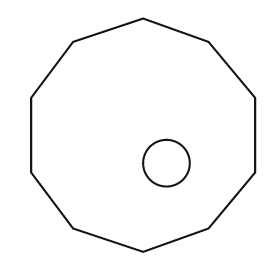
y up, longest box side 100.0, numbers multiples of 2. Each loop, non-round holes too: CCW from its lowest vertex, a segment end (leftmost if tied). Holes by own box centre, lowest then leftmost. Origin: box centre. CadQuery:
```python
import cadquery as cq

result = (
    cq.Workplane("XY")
    .moveTo(0.0, -50.0)
    .lineTo(28.0, -40.0)
    .lineTo(48.0, -16.0)
    .lineTo(48.0, 16.0)
    .lineTo(28.0, 40.0)
    .lineTo(0.0, 50.0)
    .lineTo(-30.0, 40.0)
    .lineTo(-48.0, 16.0)
    .lineTo(-48.0, -16.0)
    .lineTo(-30.0, -40.0)
    .close()
    .moveTo(10.0, -12.0)
    .circle(10.0)
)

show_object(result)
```